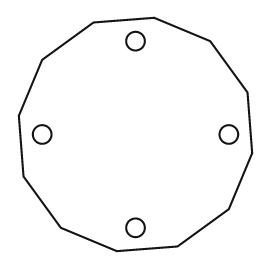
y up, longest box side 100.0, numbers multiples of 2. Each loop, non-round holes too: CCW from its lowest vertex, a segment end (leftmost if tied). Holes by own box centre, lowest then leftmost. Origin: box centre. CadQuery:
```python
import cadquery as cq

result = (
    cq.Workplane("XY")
    .moveTo(-8.0, -50.0)
    .lineTo(18.0, -48.0)
    .lineTo(40.0, -32.0)
    .lineTo(50.0, -8.0)
    .lineTo(48.0, 18.0)
    .lineTo(32.0, 40.0)
    .lineTo(8.0, 50.0)
    .lineTo(-18.0, 48.0)
    .lineTo(-40.0, 32.0)
    .lineTo(-50.0, 8.0)
    .lineTo(-48.0, -18.0)
    .lineTo(-32.0, -40.0)
    .close()
    .moveTo(0.0, -40.0)
    .circle(4.0)
    .moveTo(-40.0, 0.0)
    .circle(4.0)
    .moveTo(40.0, 0.0)
    .circle(4.0)
    .moveTo(0.0, 40.0)
    .circle(4.0)
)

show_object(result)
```